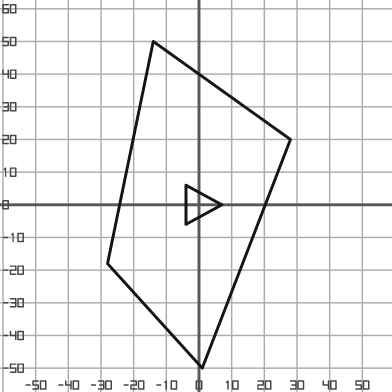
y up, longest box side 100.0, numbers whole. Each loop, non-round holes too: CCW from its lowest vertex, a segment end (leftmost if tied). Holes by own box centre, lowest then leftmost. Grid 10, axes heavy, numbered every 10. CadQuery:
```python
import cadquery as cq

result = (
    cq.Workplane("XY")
    .moveTo(1.0, -50.0)
    .lineTo(28.0, 20.0)
    .lineTo(-14.0, 50.0)
    .lineTo(-28.0, -18.0)
    .close()
    .moveTo(-4.0, -6.0)
    .lineTo(7.0, 0.0)
    .lineTo(-4.0, 6.0)
    .close()
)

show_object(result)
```